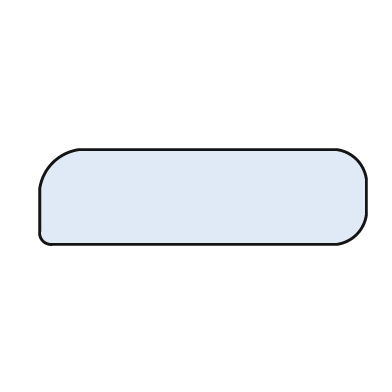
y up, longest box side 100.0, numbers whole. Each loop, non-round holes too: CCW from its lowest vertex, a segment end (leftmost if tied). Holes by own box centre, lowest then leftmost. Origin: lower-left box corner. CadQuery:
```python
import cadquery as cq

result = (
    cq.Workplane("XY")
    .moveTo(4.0, 0.0)
    .lineTo(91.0, 0.0)
    .threePointArc((97.0, 3.0), (100.0, 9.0))
    .lineTo(100.0, 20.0)
    .threePointArc((97.0, 26.0), (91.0, 29.0))
    .lineTo(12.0, 29.0)
    .threePointArc((4.0, 25.0), (0.0, 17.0))
    .lineTo(0.0, 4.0)
    .threePointArc((1.0, 1.0), (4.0, 0.0))
    .close()
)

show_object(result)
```